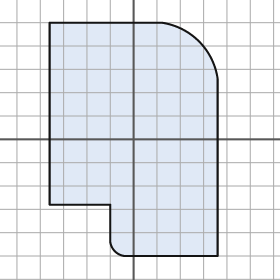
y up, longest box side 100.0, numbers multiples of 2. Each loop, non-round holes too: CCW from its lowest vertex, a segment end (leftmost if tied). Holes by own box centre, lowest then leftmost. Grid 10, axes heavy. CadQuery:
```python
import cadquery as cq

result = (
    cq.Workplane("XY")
    .moveTo(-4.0, -50.0)
    .lineTo(36.0, -50.0)
    .lineTo(36.0, 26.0)
    .threePointArc((28.0, 42.0), (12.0, 50.0))
    .lineTo(-36.0, 50.0)
    .lineTo(-36.0, -28.0)
    .lineTo(-10.0, -28.0)
    .lineTo(-10.0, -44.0)
    .threePointArc((-8.0, -48.0), (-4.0, -50.0))
    .close()
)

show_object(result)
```